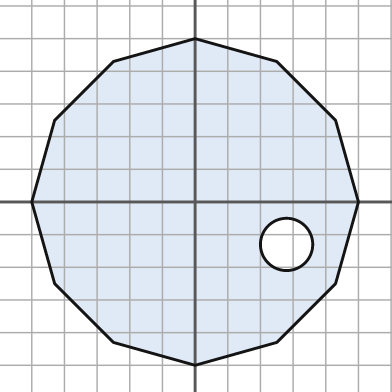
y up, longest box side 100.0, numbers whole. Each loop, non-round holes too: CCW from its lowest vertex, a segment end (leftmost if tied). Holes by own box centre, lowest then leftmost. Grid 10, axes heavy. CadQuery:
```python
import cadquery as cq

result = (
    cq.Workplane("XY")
    .moveTo(0.0, -50.0)
    .lineTo(25.0, -43.0)
    .lineTo(43.0, -25.0)
    .lineTo(50.0, 0.0)
    .lineTo(43.0, 25.0)
    .lineTo(25.0, 43.0)
    .lineTo(0.0, 50.0)
    .lineTo(-25.0, 43.0)
    .lineTo(-43.0, 25.0)
    .lineTo(-50.0, 0.0)
    .lineTo(-43.0, -25.0)
    .lineTo(-25.0, -43.0)
    .close()
    .moveTo(28.0, -13.0)
    .circle(8.0)
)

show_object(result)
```